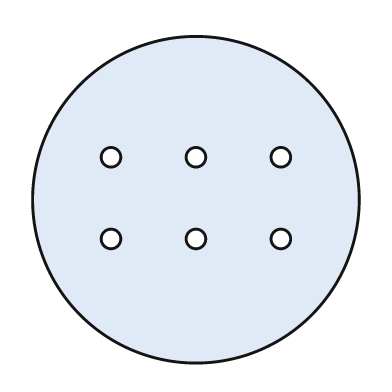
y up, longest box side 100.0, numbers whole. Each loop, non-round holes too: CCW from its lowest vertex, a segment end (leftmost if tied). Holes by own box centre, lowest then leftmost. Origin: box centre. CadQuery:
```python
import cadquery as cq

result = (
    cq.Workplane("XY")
    .moveTo(0.0, 0.0)
    .circle(50.0)
    .moveTo(-26.0, -12.0)
    .circle(3.0)
    .moveTo(0.0, -12.0)
    .circle(3.0)
    .moveTo(26.0, -12.0)
    .circle(3.0)
    .moveTo(-26.0, 13.0)
    .circle(3.0)
    .moveTo(0.0, 13.0)
    .circle(3.0)
    .moveTo(26.0, 13.0)
    .circle(3.0)
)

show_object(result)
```